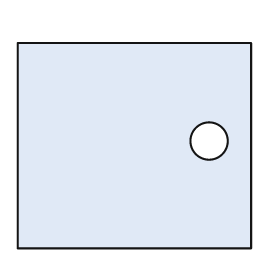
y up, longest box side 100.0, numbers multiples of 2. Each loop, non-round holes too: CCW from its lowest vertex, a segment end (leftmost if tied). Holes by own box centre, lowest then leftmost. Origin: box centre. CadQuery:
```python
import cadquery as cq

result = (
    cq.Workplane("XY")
    .moveTo(-50.0, -44.0)
    .lineTo(50.0, -44.0)
    .lineTo(50.0, 44.0)
    .lineTo(-50.0, 44.0)
    .close()
    .moveTo(32.0, 2.0)
    .circle(8.0)
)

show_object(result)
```